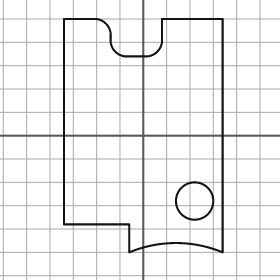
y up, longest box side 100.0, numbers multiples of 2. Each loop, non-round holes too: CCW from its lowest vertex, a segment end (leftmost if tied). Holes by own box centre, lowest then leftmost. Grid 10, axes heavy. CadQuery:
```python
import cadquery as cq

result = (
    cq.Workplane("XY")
    .moveTo(-6.0, -50.0)
    .threePointArc((14.0, -46.0), (34.0, -50.0))
    .lineTo(34.0, 50.0)
    .lineTo(8.0, 50.0)
    .lineTo(8.0, 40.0)
    .threePointArc((6.0, 36.0), (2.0, 34.0))
    .lineTo(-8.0, 34.0)
    .threePointArc((-12.0, 36.0), (-14.0, 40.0))
    .lineTo(-14.0, 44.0)
    .threePointArc((-16.0, 48.0), (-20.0, 50.0))
    .lineTo(-34.0, 50.0)
    .lineTo(-34.0, -38.0)
    .lineTo(-6.0, -38.0)
    .close()
    .moveTo(22.0, -28.0)
    .circle(8.0)
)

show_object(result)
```